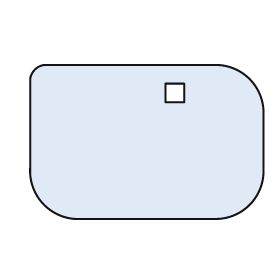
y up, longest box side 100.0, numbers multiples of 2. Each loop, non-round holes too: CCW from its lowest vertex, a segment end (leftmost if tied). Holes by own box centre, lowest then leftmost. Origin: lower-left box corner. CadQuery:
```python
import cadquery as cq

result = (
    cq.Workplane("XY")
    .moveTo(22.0, 0.0)
    .lineTo(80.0, 0.0)
    .threePointArc((94.0, 6.0), (100.0, 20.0))
    .lineTo(100.0, 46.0)
    .threePointArc((94.0, 60.0), (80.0, 66.0))
    .lineTo(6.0, 66.0)
    .threePointArc((2.0, 64.0), (0.0, 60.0))
    .lineTo(0.0, 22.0)
    .threePointArc((6.0, 6.0), (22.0, 0.0))
    .close()
    .moveTo(58.0, 50.0)
    .lineTo(66.0, 50.0)
    .lineTo(66.0, 58.0)
    .lineTo(58.0, 58.0)
    .close()
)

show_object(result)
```